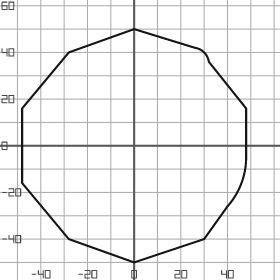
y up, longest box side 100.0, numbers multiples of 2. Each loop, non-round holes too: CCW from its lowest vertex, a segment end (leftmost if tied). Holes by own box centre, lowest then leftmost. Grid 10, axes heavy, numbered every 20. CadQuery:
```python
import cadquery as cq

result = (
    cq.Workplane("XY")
    .moveTo(0.0, -50.0)
    .lineTo(30.0, -40.0)
    .lineTo(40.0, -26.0)
    .threePointArc((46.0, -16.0), (48.0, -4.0))
    .lineTo(48.0, 16.0)
    .lineTo(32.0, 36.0)
    .threePointArc((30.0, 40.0), (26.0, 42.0))
    .lineTo(0.0, 50.0)
    .lineTo(-28.0, 40.0)
    .lineTo(-48.0, 16.0)
    .lineTo(-48.0, -16.0)
    .lineTo(-28.0, -40.0)
    .close()
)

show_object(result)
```